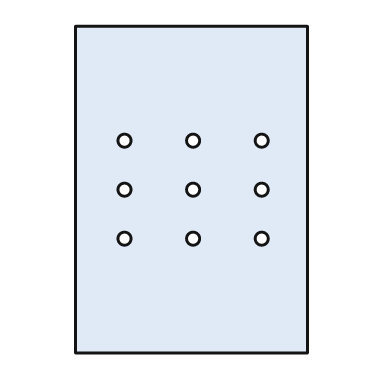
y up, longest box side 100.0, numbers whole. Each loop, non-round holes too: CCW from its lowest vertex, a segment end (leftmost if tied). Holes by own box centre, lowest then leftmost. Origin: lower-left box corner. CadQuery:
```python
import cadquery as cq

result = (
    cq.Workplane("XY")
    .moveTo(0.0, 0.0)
    .lineTo(71.0, 0.0)
    .lineTo(71.0, 100.0)
    .lineTo(0.0, 100.0)
    .close()
    .moveTo(15.0, 35.0)
    .circle(2.0)
    .moveTo(36.0, 35.0)
    .circle(2.0)
    .moveTo(57.0, 35.0)
    .circle(2.0)
    .moveTo(15.0, 50.0)
    .circle(2.0)
    .moveTo(36.0, 50.0)
    .circle(2.0)
    .moveTo(57.0, 50.0)
    .circle(2.0)
    .moveTo(15.0, 65.0)
    .circle(2.0)
    .moveTo(36.0, 65.0)
    .circle(2.0)
    .moveTo(57.0, 65.0)
    .circle(2.0)
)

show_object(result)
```